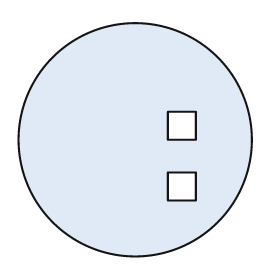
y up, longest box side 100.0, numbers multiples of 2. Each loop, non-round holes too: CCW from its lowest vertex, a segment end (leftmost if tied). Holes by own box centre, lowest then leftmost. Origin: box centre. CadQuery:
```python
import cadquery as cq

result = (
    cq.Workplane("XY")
    .moveTo(0.0, 0.0)
    .circle(50.0)
    .moveTo(14.0, -26.0)
    .lineTo(26.0, -26.0)
    .lineTo(26.0, -14.0)
    .lineTo(14.0, -14.0)
    .close()
    .moveTo(14.0, 0.0)
    .lineTo(26.0, 0.0)
    .lineTo(26.0, 12.0)
    .lineTo(14.0, 12.0)
    .close()
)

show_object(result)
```